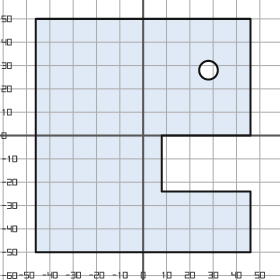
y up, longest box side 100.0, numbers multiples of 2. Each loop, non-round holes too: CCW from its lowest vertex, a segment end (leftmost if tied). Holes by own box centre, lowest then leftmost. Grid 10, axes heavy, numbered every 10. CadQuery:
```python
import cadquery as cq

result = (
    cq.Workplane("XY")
    .moveTo(-46.0, -50.0)
    .lineTo(46.0, -50.0)
    .lineTo(46.0, -24.0)
    .lineTo(8.0, -24.0)
    .lineTo(8.0, 0.0)
    .lineTo(46.0, 0.0)
    .lineTo(46.0, 50.0)
    .lineTo(-46.0, 50.0)
    .close()
    .moveTo(28.0, 28.0)
    .circle(4.0)
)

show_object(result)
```